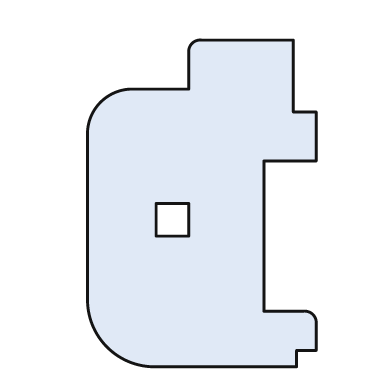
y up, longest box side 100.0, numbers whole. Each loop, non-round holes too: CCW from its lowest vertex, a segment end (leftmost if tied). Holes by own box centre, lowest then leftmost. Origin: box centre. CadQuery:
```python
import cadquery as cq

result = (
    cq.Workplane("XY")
    .moveTo(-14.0, -50.0)
    .lineTo(29.0, -50.0)
    .lineTo(29.0, -45.0)
    .lineTo(35.0, -45.0)
    .lineTo(35.0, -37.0)
    .threePointArc((34.0, -34.0), (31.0, -33.0))
    .lineTo(19.0, -33.0)
    .lineTo(19.0, 13.0)
    .lineTo(35.0, 13.0)
    .lineTo(35.0, 28.0)
    .lineTo(28.0, 28.0)
    .lineTo(28.0, 50.0)
    .lineTo(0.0, 50.0)
    .threePointArc((-3.0, 49.0), (-4.0, 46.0))
    .lineTo(-4.0, 35.0)
    .lineTo(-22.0, 35.0)
    .threePointArc((-31.0, 31.0), (-35.0, 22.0))
    .lineTo(-35.0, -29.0)
    .threePointArc((-29.0, -44.0), (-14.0, -50.0))
    .close()
    .moveTo(-14.0, -10.0)
    .lineTo(-4.0, -10.0)
    .lineTo(-4.0, 0.0)
    .lineTo(-14.0, 0.0)
    .close()
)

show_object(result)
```